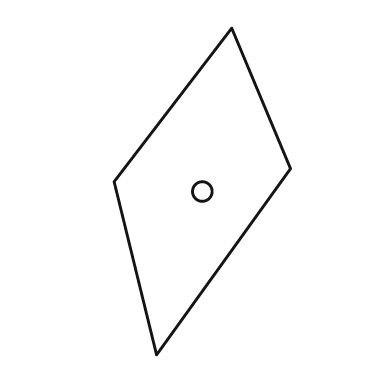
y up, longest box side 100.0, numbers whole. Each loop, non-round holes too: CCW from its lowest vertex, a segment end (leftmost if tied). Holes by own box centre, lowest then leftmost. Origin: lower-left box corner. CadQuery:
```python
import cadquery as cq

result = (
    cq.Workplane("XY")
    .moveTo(13.0, 0.0)
    .lineTo(54.0, 57.0)
    .lineTo(36.0, 100.0)
    .lineTo(0.0, 53.0)
    .close()
    .moveTo(27.0, 50.0)
    .circle(3.0)
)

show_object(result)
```